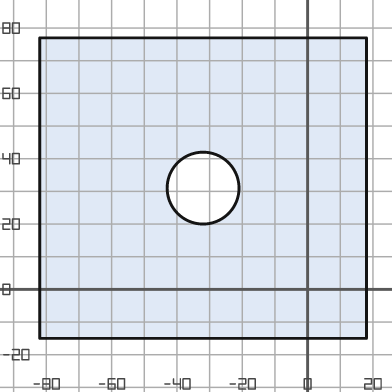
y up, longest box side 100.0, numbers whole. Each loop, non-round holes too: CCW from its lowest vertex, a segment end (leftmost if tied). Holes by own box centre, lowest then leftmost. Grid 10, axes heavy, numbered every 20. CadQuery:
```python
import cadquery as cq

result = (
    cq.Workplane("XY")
    .moveTo(-82.0, -15.0)
    .lineTo(18.0, -15.0)
    .lineTo(18.0, 77.0)
    .lineTo(-82.0, 77.0)
    .close()
    .moveTo(-32.0, 31.0)
    .circle(11.0)
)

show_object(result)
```